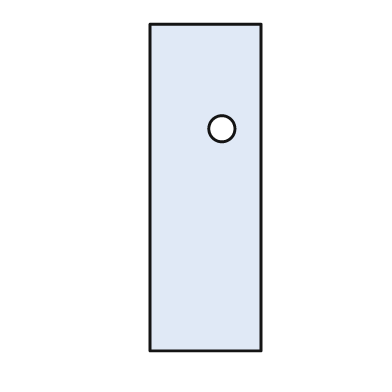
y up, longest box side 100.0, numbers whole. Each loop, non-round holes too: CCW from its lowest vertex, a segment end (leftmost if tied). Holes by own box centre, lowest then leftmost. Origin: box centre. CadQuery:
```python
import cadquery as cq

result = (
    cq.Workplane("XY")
    .moveTo(-17.0, -50.0)
    .lineTo(17.0, -50.0)
    .lineTo(17.0, 50.0)
    .lineTo(-17.0, 50.0)
    .close()
    .moveTo(5.0, 18.0)
    .circle(4.0)
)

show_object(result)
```